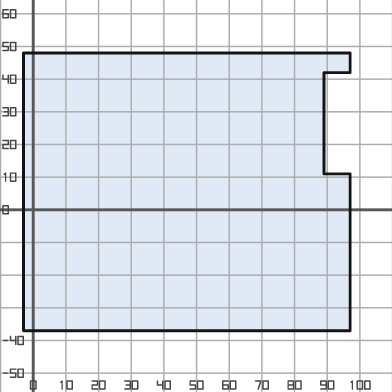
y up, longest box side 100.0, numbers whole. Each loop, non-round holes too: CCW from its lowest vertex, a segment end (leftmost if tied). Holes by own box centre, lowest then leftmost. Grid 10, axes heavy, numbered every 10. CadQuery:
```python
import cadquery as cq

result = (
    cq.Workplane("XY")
    .moveTo(-3.0, -37.0)
    .lineTo(97.0, -37.0)
    .lineTo(97.0, 11.0)
    .lineTo(89.0, 11.0)
    .lineTo(89.0, 42.0)
    .lineTo(97.0, 42.0)
    .lineTo(97.0, 48.0)
    .lineTo(-3.0, 48.0)
    .close()
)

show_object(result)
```